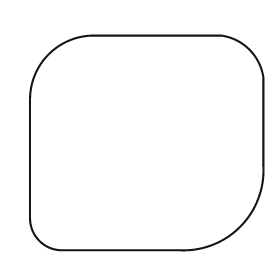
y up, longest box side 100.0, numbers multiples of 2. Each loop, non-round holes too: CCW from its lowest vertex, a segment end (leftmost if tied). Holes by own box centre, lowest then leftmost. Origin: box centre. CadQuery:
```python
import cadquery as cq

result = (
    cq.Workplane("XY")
    .moveTo(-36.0, -46.0)
    .lineTo(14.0, -46.0)
    .threePointArc((40.0, -36.0), (50.0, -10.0))
    .lineTo(50.0, 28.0)
    .threePointArc((44.0, 40.0), (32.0, 46.0))
    .lineTo(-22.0, 46.0)
    .threePointArc((-42.0, 38.0), (-50.0, 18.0))
    .lineTo(-50.0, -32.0)
    .threePointArc((-46.0, -42.0), (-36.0, -46.0))
    .close()
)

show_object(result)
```